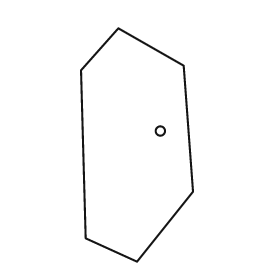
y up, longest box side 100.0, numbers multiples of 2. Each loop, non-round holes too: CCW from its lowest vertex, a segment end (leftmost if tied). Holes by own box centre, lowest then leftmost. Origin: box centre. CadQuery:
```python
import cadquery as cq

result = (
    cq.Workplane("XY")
    .moveTo(0.0, -50.0)
    .lineTo(24.0, -20.0)
    .lineTo(20.0, 34.0)
    .lineTo(-8.0, 50.0)
    .lineTo(-24.0, 32.0)
    .lineTo(-22.0, -40.0)
    .close()
    .moveTo(10.0, 6.0)
    .circle(2.0)
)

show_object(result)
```